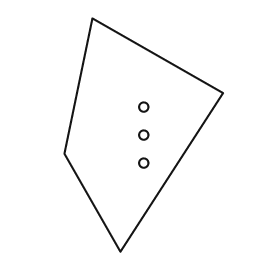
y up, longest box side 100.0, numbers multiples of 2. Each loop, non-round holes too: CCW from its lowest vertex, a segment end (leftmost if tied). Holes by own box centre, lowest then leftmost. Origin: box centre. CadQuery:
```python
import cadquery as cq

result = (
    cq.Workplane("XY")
    .moveTo(-10.0, -50.0)
    .lineTo(34.0, 18.0)
    .lineTo(-22.0, 50.0)
    .lineTo(-34.0, -8.0)
    .close()
    .moveTo(0.0, -12.0)
    .circle(2.0)
    .moveTo(0.0, 0.0)
    .circle(2.0)
    .moveTo(0.0, 12.0)
    .circle(2.0)
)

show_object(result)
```